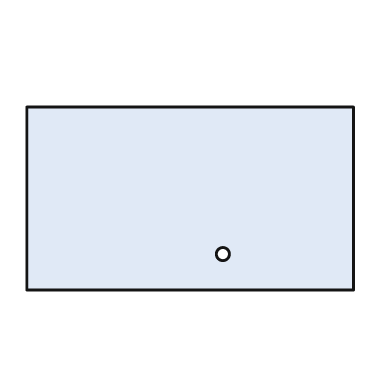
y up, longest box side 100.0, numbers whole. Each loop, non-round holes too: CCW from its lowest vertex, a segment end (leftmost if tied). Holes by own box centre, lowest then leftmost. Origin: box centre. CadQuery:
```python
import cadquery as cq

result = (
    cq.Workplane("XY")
    .moveTo(-50.0, -28.0)
    .lineTo(50.0, -28.0)
    .lineTo(50.0, 28.0)
    .lineTo(-50.0, 28.0)
    .close()
    .moveTo(10.0, -17.0)
    .circle(2.0)
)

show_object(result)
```